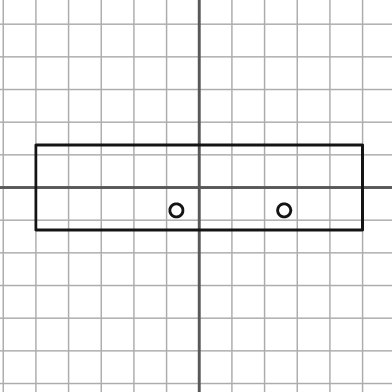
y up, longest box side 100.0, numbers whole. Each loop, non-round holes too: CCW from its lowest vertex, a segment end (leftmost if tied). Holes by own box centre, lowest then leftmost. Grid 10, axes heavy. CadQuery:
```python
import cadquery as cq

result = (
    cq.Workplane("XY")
    .moveTo(-50.0, -13.0)
    .lineTo(50.0, -13.0)
    .lineTo(50.0, 13.0)
    .lineTo(-50.0, 13.0)
    .close()
    .moveTo(-7.0, -7.0)
    .circle(2.0)
    .moveTo(26.0, -7.0)
    .circle(2.0)
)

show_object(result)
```